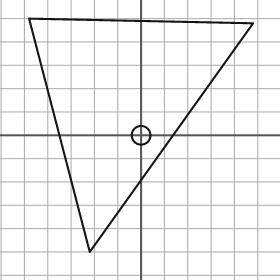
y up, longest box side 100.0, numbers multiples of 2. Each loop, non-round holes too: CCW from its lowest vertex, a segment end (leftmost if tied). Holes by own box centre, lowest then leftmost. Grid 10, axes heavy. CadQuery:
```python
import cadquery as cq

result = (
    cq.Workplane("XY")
    .moveTo(-22.0, -50.0)
    .lineTo(48.0, 48.0)
    .lineTo(-48.0, 50.0)
    .close()
    .moveTo(0.0, 0.0)
    .circle(4.0)
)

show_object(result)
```